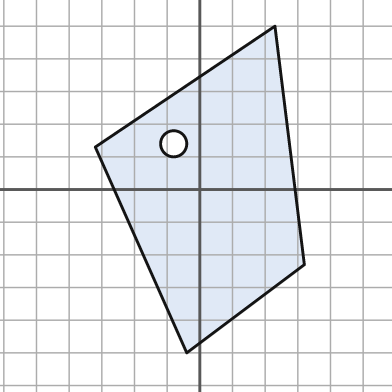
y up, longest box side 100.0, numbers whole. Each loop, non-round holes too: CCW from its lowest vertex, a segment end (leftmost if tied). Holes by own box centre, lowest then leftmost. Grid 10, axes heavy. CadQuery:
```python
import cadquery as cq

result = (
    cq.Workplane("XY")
    .moveTo(-4.0, -50.0)
    .lineTo(32.0, -23.0)
    .lineTo(23.0, 50.0)
    .lineTo(-32.0, 13.0)
    .close()
    .moveTo(-8.0, 14.0)
    .circle(4.0)
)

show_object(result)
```